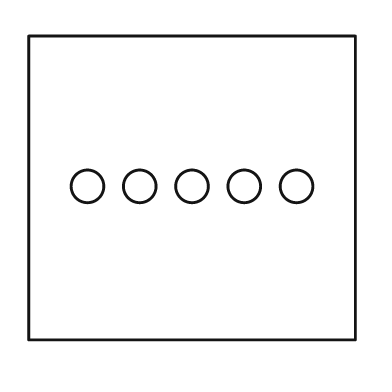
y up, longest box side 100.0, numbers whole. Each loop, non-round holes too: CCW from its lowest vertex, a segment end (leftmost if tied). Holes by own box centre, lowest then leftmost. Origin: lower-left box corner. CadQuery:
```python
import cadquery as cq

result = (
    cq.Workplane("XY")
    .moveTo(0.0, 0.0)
    .lineTo(100.0, 0.0)
    .lineTo(100.0, 93.0)
    .lineTo(0.0, 93.0)
    .close()
    .moveTo(18.0, 47.0)
    .circle(5.0)
    .moveTo(34.0, 47.0)
    .circle(5.0)
    .moveTo(50.0, 47.0)
    .circle(5.0)
    .moveTo(66.0, 47.0)
    .circle(5.0)
    .moveTo(82.0, 47.0)
    .circle(5.0)
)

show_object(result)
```